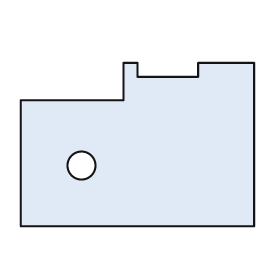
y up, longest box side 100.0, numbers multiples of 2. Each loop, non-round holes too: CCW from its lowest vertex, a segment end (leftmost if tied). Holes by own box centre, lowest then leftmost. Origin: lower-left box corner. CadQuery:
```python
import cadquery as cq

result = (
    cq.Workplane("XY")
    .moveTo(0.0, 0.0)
    .lineTo(100.0, 0.0)
    .lineTo(100.0, 70.0)
    .lineTo(76.0, 70.0)
    .lineTo(76.0, 64.0)
    .lineTo(50.0, 64.0)
    .lineTo(50.0, 70.0)
    .lineTo(44.0, 70.0)
    .lineTo(44.0, 54.0)
    .lineTo(0.0, 54.0)
    .close()
    .moveTo(26.0, 26.0)
    .circle(6.0)
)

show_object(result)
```